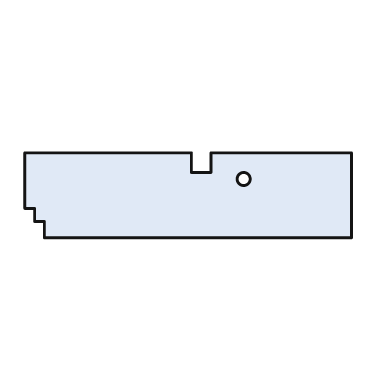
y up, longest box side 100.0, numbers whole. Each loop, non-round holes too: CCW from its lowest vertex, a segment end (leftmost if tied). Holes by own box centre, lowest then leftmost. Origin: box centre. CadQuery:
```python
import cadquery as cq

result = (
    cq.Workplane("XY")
    .moveTo(-44.0, -13.0)
    .lineTo(50.0, -13.0)
    .lineTo(50.0, 13.0)
    .lineTo(7.0, 13.0)
    .lineTo(7.0, 7.0)
    .lineTo(1.0, 7.0)
    .lineTo(1.0, 13.0)
    .lineTo(-50.0, 13.0)
    .lineTo(-50.0, -4.0)
    .lineTo(-47.0, -4.0)
    .lineTo(-47.0, -8.0)
    .lineTo(-44.0, -8.0)
    .close()
    .moveTo(17.0, 5.0)
    .circle(2.0)
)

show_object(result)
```